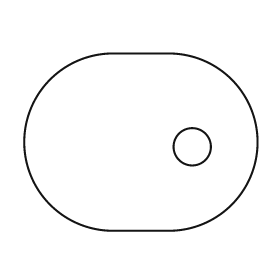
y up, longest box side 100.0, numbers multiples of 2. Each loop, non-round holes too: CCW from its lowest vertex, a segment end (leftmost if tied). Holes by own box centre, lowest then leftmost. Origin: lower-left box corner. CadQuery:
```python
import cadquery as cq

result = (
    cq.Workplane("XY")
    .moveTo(38.0, 0.0)
    .lineTo(62.0, 0.0)
    .threePointArc((100.0, 38.0), (62.0, 76.0))
    .lineTo(38.0, 76.0)
    .threePointArc((0.0, 38.0), (38.0, 0.0))
    .close()
    .moveTo(72.0, 36.0)
    .circle(8.0)
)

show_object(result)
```